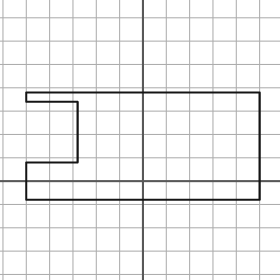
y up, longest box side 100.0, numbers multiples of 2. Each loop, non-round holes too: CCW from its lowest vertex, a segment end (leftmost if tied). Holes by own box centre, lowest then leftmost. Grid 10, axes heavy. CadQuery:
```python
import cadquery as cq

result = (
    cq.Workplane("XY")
    .moveTo(-50.0, -8.0)
    .lineTo(50.0, -8.0)
    .lineTo(50.0, 38.0)
    .lineTo(-50.0, 38.0)
    .lineTo(-50.0, 34.0)
    .lineTo(-28.0, 34.0)
    .lineTo(-28.0, 8.0)
    .lineTo(-50.0, 8.0)
    .close()
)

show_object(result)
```